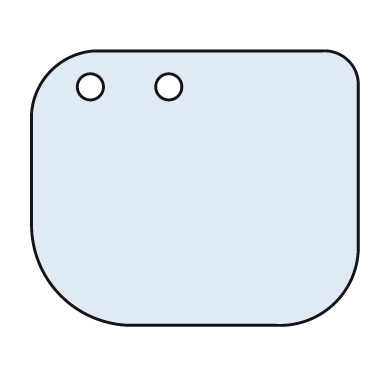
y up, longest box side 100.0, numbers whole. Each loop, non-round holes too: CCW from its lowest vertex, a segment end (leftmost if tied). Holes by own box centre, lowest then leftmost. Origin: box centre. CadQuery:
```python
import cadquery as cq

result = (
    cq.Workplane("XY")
    .moveTo(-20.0, -42.0)
    .lineTo(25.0, -42.0)
    .threePointArc((43.0, -35.0), (50.0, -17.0))
    .lineTo(50.0, 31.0)
    .threePointArc((47.0, 39.0), (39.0, 42.0))
    .lineTo(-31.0, 42.0)
    .threePointArc((-44.0, 36.0), (-50.0, 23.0))
    .lineTo(-50.0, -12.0)
    .threePointArc((-41.0, -33.0), (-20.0, -42.0))
    .close()
    .moveTo(-32.0, 31.0)
    .circle(4.0)
    .moveTo(-8.0, 31.0)
    .circle(4.0)
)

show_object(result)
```